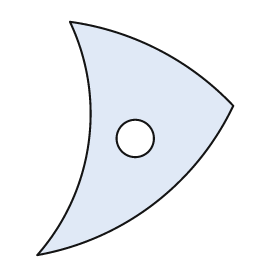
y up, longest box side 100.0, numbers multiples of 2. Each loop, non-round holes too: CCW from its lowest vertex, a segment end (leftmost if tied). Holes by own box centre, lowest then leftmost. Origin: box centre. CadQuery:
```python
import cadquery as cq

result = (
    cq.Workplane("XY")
    .moveTo(-42.0, -50.0)
    .threePointArc((8.0, -28.0), (42.0, 14.0))
    .threePointArc((10.0, 38.0), (-28.0, 50.0))
    .threePointArc((-20.0, -2.0), (-42.0, -50.0))
    .close()
    .moveTo(0.0, 0.0)
    .circle(8.0)
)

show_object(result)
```